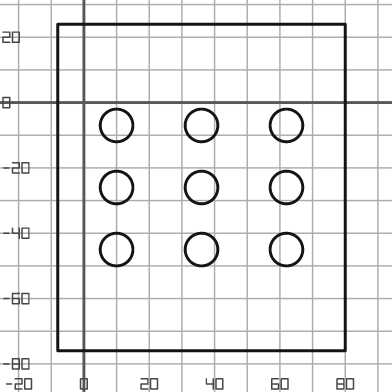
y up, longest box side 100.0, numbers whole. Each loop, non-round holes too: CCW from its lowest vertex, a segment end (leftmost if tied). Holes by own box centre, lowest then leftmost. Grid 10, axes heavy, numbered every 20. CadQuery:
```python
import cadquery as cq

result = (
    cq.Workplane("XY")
    .moveTo(-8.0, -76.0)
    .lineTo(80.0, -76.0)
    .lineTo(80.0, 24.0)
    .lineTo(-8.0, 24.0)
    .close()
    .moveTo(10.0, -45.0)
    .circle(5.0)
    .moveTo(36.0, -45.0)
    .circle(5.0)
    .moveTo(62.0, -45.0)
    .circle(5.0)
    .moveTo(10.0, -26.0)
    .circle(5.0)
    .moveTo(36.0, -26.0)
    .circle(5.0)
    .moveTo(62.0, -26.0)
    .circle(5.0)
    .moveTo(10.0, -7.0)
    .circle(5.0)
    .moveTo(36.0, -7.0)
    .circle(5.0)
    .moveTo(62.0, -7.0)
    .circle(5.0)
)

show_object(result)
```